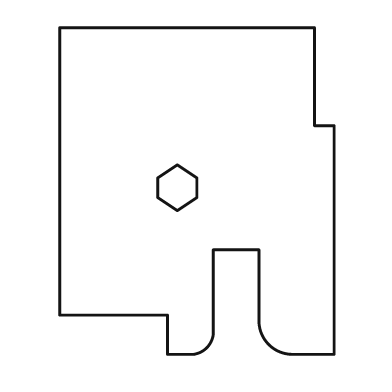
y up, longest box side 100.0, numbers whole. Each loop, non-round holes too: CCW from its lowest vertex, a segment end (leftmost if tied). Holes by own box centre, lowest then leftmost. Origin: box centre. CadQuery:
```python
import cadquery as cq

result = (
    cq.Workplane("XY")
    .moveTo(-9.0, -50.0)
    .lineTo(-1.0, -50.0)
    .threePointArc((3.0, -48.0), (5.0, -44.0))
    .lineTo(5.0, -18.0)
    .lineTo(19.0, -18.0)
    .lineTo(19.0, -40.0)
    .threePointArc((22.0, -47.0), (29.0, -50.0))
    .lineTo(42.0, -50.0)
    .lineTo(42.0, 20.0)
    .lineTo(36.0, 20.0)
    .lineTo(36.0, 50.0)
    .lineTo(-42.0, 50.0)
    .lineTo(-42.0, -38.0)
    .lineTo(-9.0, -38.0)
    .close()
    .moveTo(-6.0, -6.0)
    .lineTo(0.0, -2.0)
    .lineTo(0.0, 4.0)
    .lineTo(-6.0, 8.0)
    .lineTo(-12.0, 4.0)
    .lineTo(-12.0, -2.0)
    .close()
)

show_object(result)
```